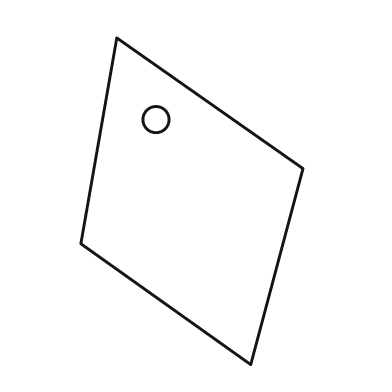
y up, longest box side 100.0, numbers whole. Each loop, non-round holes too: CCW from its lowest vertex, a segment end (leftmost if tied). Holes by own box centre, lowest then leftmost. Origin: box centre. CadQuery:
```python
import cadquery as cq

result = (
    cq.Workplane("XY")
    .moveTo(18.0, -50.0)
    .lineTo(34.0, 10.0)
    .lineTo(-23.0, 50.0)
    .lineTo(-34.0, -13.0)
    .close()
    .moveTo(-11.0, 25.0)
    .circle(4.0)
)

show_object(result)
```